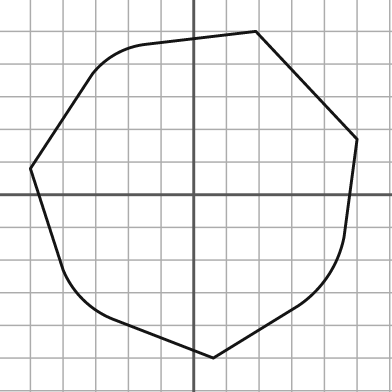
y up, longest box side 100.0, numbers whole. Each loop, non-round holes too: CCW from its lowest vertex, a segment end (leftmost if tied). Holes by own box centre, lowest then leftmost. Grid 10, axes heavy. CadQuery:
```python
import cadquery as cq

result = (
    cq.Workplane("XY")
    .moveTo(6.0, -50.0)
    .lineTo(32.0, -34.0)
    .threePointArc((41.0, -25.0), (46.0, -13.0))
    .lineTo(50.0, 17.0)
    .lineTo(19.0, 50.0)
    .lineTo(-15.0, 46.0)
    .threePointArc((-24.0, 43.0), (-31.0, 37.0))
    .lineTo(-50.0, 8.0)
    .lineTo(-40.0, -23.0)
    .threePointArc((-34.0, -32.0), (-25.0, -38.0))
    .close()
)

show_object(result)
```